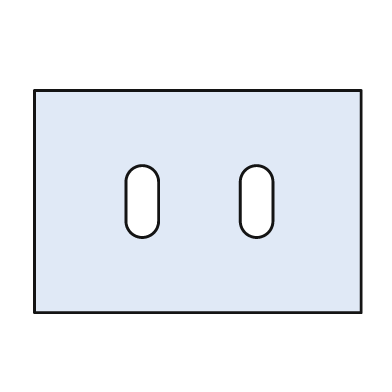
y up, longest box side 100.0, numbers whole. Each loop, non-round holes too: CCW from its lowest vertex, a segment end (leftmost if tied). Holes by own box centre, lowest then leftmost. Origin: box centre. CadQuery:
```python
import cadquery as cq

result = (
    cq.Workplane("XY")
    .moveTo(-50.0, -34.0)
    .lineTo(50.0, -34.0)
    .lineTo(50.0, 34.0)
    .lineTo(-50.0, 34.0)
    .close()
    .moveTo(-22.0, -6.0)
    .threePointArc((-17.0, -11.0), (-12.0, -6.0))
    .lineTo(-12.0, 6.0)
    .threePointArc((-17.0, 11.0), (-22.0, 6.0))
    .close()
    .moveTo(13.0, -6.0)
    .threePointArc((18.0, -11.0), (23.0, -6.0))
    .lineTo(23.0, 6.0)
    .threePointArc((18.0, 11.0), (13.0, 6.0))
    .close()
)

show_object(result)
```